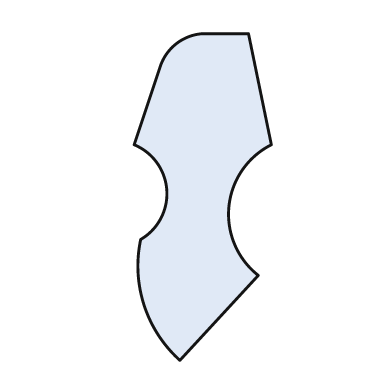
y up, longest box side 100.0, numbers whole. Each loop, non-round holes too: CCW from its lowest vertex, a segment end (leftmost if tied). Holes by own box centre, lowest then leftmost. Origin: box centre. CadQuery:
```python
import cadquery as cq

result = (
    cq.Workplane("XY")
    .moveTo(-7.0, -50.0)
    .lineTo(17.0, -24.0)
    .threePointArc((8.0, -3.0), (21.0, 16.0))
    .lineTo(14.0, 50.0)
    .lineTo(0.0, 50.0)
    .threePointArc((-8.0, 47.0), (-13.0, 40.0))
    .lineTo(-21.0, 16.0)
    .threePointArc((-11.0, 2.0), (-19.0, -13.0))
    .threePointArc((-18.0, -33.0), (-7.0, -50.0))
    .close()
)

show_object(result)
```